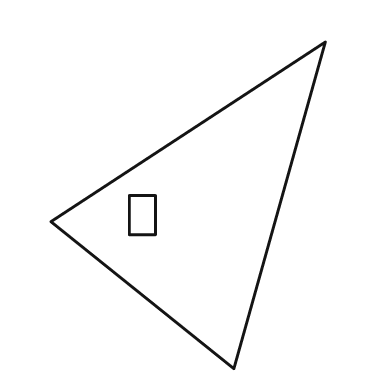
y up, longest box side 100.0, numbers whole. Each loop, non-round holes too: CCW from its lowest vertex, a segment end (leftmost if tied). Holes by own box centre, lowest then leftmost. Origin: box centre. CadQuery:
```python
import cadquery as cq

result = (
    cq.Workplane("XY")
    .moveTo(14.0, -50.0)
    .lineTo(42.0, 50.0)
    .lineTo(-42.0, -5.0)
    .close()
    .moveTo(-18.0, -9.0)
    .lineTo(-10.0, -9.0)
    .lineTo(-10.0, 3.0)
    .lineTo(-18.0, 3.0)
    .close()
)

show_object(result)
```